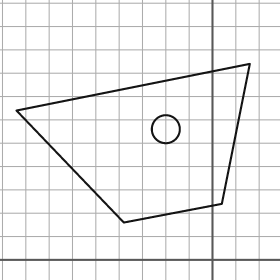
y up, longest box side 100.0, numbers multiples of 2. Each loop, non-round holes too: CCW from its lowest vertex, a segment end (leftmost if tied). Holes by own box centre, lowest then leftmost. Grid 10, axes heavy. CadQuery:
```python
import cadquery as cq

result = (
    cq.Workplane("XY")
    .moveTo(-38.0, 16.0)
    .lineTo(4.0, 24.0)
    .lineTo(16.0, 84.0)
    .lineTo(-84.0, 64.0)
    .close()
    .moveTo(-20.0, 56.0)
    .circle(6.0)
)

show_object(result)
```